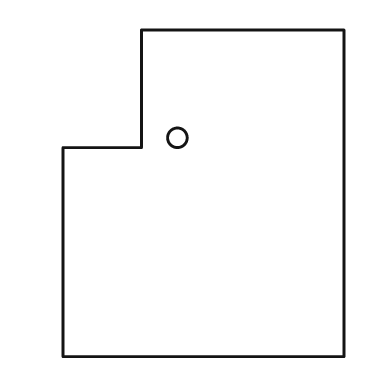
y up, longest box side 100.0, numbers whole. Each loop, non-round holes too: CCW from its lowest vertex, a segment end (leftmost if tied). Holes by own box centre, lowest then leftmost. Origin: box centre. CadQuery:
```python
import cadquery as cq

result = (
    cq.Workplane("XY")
    .moveTo(-43.0, -50.0)
    .lineTo(43.0, -50.0)
    .lineTo(43.0, 50.0)
    .lineTo(-19.0, 50.0)
    .lineTo(-19.0, 14.0)
    .lineTo(-43.0, 14.0)
    .close()
    .moveTo(-8.0, 17.0)
    .circle(3.0)
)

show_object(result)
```